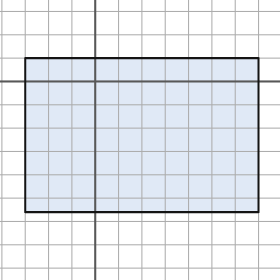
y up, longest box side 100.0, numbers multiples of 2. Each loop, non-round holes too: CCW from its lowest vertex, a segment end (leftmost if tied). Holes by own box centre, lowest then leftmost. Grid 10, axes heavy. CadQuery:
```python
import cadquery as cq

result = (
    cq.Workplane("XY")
    .moveTo(-30.0, -56.0)
    .lineTo(70.0, -56.0)
    .lineTo(70.0, 10.0)
    .lineTo(-30.0, 10.0)
    .close()
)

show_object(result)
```